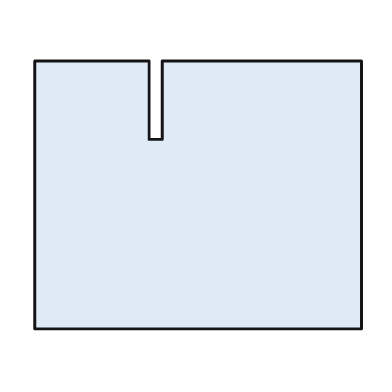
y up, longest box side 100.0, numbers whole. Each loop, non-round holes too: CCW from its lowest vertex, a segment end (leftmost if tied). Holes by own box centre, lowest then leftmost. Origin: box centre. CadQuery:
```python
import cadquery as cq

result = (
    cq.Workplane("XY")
    .moveTo(-50.0, -41.0)
    .lineTo(50.0, -41.0)
    .lineTo(50.0, 41.0)
    .lineTo(-11.0, 41.0)
    .lineTo(-11.0, 17.0)
    .lineTo(-15.0, 17.0)
    .lineTo(-15.0, 41.0)
    .lineTo(-50.0, 41.0)
    .close()
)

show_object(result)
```